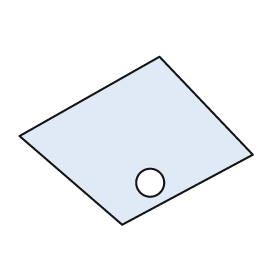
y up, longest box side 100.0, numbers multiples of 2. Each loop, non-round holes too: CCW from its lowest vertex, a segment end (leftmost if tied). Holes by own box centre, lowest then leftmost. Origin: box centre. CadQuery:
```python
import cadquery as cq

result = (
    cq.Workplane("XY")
    .moveTo(-6.0, -36.0)
    .lineTo(50.0, -6.0)
    .lineTo(10.0, 36.0)
    .lineTo(-50.0, 2.0)
    .close()
    .moveTo(6.0, -18.0)
    .circle(6.0)
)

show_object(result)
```